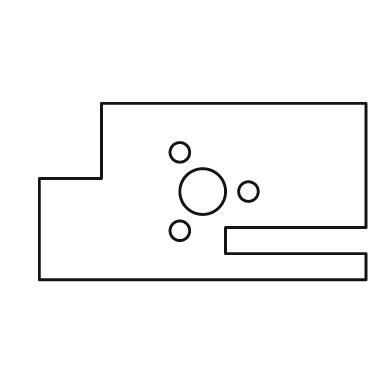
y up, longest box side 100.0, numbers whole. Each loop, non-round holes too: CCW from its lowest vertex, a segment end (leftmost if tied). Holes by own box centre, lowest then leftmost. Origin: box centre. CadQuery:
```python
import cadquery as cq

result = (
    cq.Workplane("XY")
    .moveTo(-50.0, -27.0)
    .lineTo(50.0, -27.0)
    .lineTo(50.0, -19.0)
    .lineTo(7.0, -19.0)
    .lineTo(7.0, -11.0)
    .lineTo(50.0, -11.0)
    .lineTo(50.0, 27.0)
    .lineTo(-31.0, 27.0)
    .lineTo(-31.0, 4.0)
    .lineTo(-50.0, 4.0)
    .close()
    .moveTo(-7.0, -12.0)
    .circle(3.0)
    .moveTo(0.0, 0.0)
    .circle(7.0)
    .moveTo(14.0, 0.0)
    .circle(3.0)
    .moveTo(-7.0, 12.0)
    .circle(3.0)
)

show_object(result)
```